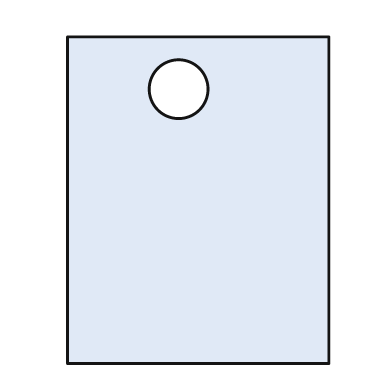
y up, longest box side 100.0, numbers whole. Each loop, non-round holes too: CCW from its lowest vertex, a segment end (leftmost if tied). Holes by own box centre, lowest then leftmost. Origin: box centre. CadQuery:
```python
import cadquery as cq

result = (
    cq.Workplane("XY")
    .moveTo(-40.0, -50.0)
    .lineTo(40.0, -50.0)
    .lineTo(40.0, 50.0)
    .lineTo(-40.0, 50.0)
    .close()
    .moveTo(-6.0, 34.0)
    .circle(9.0)
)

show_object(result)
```